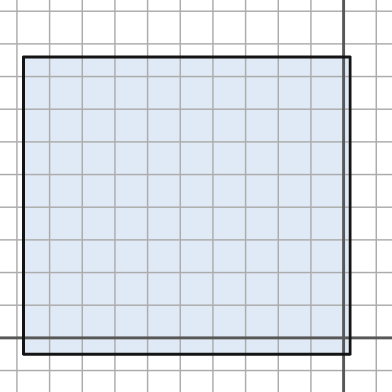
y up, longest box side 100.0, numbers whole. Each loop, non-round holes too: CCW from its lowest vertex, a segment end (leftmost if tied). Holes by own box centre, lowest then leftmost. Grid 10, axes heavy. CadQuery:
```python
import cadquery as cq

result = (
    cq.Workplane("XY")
    .moveTo(-98.0, -5.0)
    .lineTo(2.0, -5.0)
    .lineTo(2.0, 86.0)
    .lineTo(-98.0, 86.0)
    .close()
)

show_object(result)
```